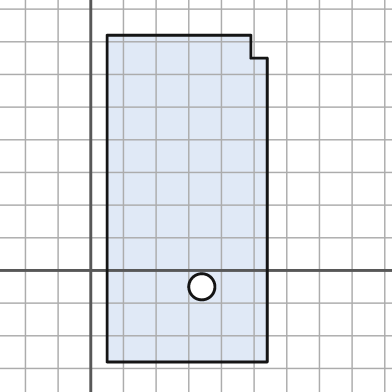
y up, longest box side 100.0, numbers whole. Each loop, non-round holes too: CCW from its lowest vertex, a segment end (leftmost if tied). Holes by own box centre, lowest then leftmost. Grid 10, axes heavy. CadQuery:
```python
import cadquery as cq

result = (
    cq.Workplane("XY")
    .moveTo(5.0, -28.0)
    .lineTo(54.0, -28.0)
    .lineTo(54.0, 65.0)
    .lineTo(49.0, 65.0)
    .lineTo(49.0, 72.0)
    .lineTo(5.0, 72.0)
    .close()
    .moveTo(34.0, -5.0)
    .circle(4.0)
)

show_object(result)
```